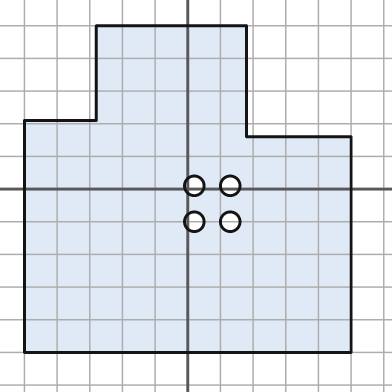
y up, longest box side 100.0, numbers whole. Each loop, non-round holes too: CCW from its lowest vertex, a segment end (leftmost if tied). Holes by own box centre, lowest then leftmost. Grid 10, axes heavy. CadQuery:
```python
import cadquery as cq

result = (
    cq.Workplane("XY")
    .moveTo(-50.0, -50.0)
    .lineTo(50.0, -50.0)
    .lineTo(50.0, 16.0)
    .lineTo(18.0, 16.0)
    .lineTo(18.0, 50.0)
    .lineTo(-28.0, 50.0)
    .lineTo(-28.0, 21.0)
    .lineTo(-50.0, 21.0)
    .close()
    .moveTo(2.0, -10.0)
    .circle(3.0)
    .moveTo(13.0, -10.0)
    .circle(3.0)
    .moveTo(2.0, 1.0)
    .circle(3.0)
    .moveTo(13.0, 1.0)
    .circle(3.0)
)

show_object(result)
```